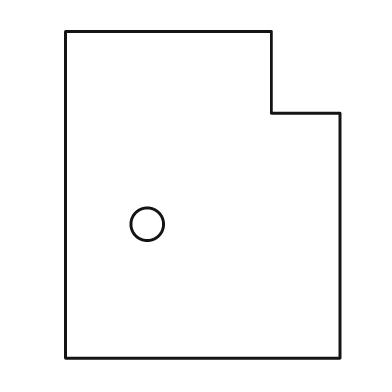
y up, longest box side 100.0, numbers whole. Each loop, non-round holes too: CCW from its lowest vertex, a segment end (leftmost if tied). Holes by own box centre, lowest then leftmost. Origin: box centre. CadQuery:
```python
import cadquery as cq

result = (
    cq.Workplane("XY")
    .moveTo(-42.0, -50.0)
    .lineTo(42.0, -50.0)
    .lineTo(42.0, 25.0)
    .lineTo(21.0, 25.0)
    .lineTo(21.0, 50.0)
    .lineTo(-42.0, 50.0)
    .close()
    .moveTo(-17.0, -9.0)
    .circle(5.0)
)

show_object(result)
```